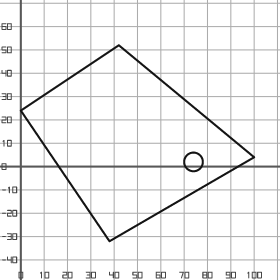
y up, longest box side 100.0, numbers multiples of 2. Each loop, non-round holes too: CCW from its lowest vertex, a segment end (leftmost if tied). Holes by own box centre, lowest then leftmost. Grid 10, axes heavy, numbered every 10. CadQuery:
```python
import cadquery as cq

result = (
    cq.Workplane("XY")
    .moveTo(38.0, -32.0)
    .lineTo(100.0, 4.0)
    .lineTo(42.0, 52.0)
    .lineTo(0.0, 24.0)
    .close()
    .moveTo(74.0, 2.0)
    .circle(4.0)
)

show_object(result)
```